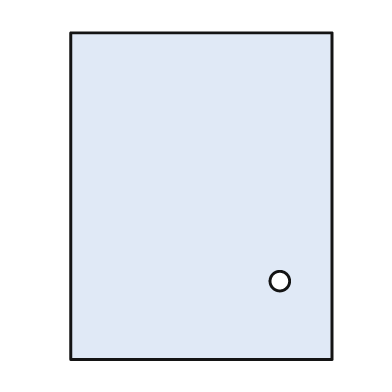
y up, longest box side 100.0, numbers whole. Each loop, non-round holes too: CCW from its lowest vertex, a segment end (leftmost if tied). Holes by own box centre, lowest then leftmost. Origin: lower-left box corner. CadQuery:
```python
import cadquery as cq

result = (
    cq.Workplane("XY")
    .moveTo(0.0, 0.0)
    .lineTo(80.0, 0.0)
    .lineTo(80.0, 100.0)
    .lineTo(0.0, 100.0)
    .close()
    .moveTo(64.0, 24.0)
    .circle(3.0)
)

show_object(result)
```